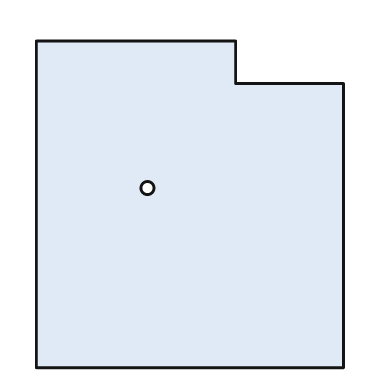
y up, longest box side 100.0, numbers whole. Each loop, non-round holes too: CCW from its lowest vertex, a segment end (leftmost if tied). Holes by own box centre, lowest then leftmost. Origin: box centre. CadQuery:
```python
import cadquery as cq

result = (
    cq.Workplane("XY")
    .moveTo(-47.0, -50.0)
    .lineTo(47.0, -50.0)
    .lineTo(47.0, 37.0)
    .lineTo(14.0, 37.0)
    .lineTo(14.0, 50.0)
    .lineTo(-47.0, 50.0)
    .close()
    .moveTo(-13.0, 5.0)
    .circle(2.0)
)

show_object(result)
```